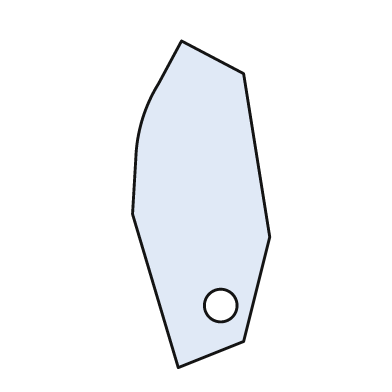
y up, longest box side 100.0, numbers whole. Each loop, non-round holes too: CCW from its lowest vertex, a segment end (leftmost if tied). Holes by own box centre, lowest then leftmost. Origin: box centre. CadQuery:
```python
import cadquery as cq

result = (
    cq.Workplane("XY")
    .moveTo(-7.0, -50.0)
    .lineTo(13.0, -42.0)
    .lineTo(21.0, -10.0)
    .lineTo(13.0, 40.0)
    .lineTo(-6.0, 50.0)
    .lineTo(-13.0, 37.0)
    .threePointArc((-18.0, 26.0), (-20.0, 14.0))
    .lineTo(-21.0, -3.0)
    .close()
    .moveTo(6.0, -31.0)
    .circle(5.0)
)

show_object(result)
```